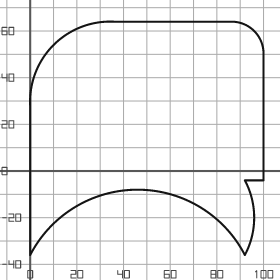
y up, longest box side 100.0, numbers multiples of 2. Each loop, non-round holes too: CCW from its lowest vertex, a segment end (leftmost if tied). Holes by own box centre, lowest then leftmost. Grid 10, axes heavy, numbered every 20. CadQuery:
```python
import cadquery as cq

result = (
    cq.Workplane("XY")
    .moveTo(0.0, -36.0)
    .threePointArc((46.0, -8.0), (92.0, -36.0))
    .threePointArc((96.0, -20.0), (92.0, -4.0))
    .lineTo(100.0, -4.0)
    .lineTo(100.0, 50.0)
    .threePointArc((96.0, 60.0), (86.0, 64.0))
    .lineTo(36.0, 64.0)
    .threePointArc((10.0, 54.0), (0.0, 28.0))
    .close()
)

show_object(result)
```